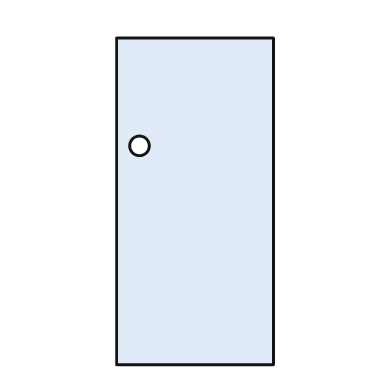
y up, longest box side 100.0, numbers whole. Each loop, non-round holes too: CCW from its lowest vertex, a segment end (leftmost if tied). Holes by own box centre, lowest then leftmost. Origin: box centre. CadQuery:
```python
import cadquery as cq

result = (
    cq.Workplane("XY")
    .moveTo(-24.0, -50.0)
    .lineTo(24.0, -50.0)
    .lineTo(24.0, 50.0)
    .lineTo(-24.0, 50.0)
    .close()
    .moveTo(-17.0, 17.0)
    .circle(3.0)
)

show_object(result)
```